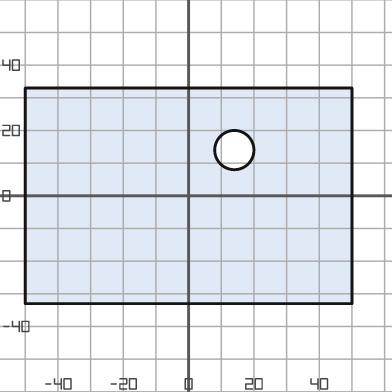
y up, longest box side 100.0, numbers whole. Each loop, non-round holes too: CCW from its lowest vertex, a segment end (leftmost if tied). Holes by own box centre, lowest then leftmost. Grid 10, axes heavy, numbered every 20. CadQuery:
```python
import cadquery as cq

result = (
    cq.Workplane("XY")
    .moveTo(-50.0, -33.0)
    .lineTo(50.0, -33.0)
    .lineTo(50.0, 33.0)
    .lineTo(-50.0, 33.0)
    .close()
    .moveTo(14.0, 14.0)
    .circle(6.0)
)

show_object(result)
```